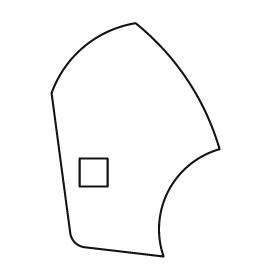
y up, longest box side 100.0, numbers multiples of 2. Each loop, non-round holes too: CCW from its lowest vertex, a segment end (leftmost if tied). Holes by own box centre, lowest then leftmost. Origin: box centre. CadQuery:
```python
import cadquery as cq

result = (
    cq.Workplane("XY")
    .moveTo(12.0, -50.0)
    .threePointArc((14.0, -22.0), (36.0, -4.0))
    .threePointArc((22.0, 26.0), (0.0, 50.0))
    .threePointArc((-22.0, 40.0), (-36.0, 20.0))
    .lineTo(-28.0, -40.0)
    .threePointArc((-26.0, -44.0), (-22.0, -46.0))
    .close()
    .moveTo(-24.0, -20.0)
    .lineTo(-12.0, -20.0)
    .lineTo(-12.0, -8.0)
    .lineTo(-24.0, -8.0)
    .close()
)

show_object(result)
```